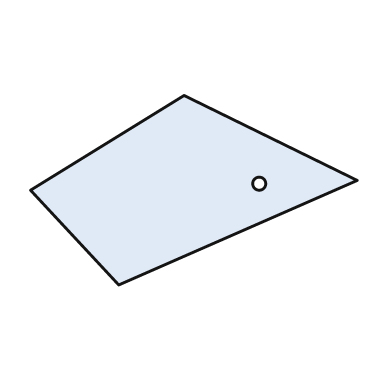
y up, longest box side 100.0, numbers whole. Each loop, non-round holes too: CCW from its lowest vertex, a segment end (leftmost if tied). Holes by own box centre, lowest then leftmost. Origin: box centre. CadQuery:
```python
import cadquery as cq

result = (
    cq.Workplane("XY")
    .moveTo(-23.0, -29.0)
    .lineTo(50.0, 3.0)
    .lineTo(-3.0, 29.0)
    .lineTo(-50.0, 0.0)
    .close()
    .moveTo(20.0, 2.0)
    .circle(2.0)
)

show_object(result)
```